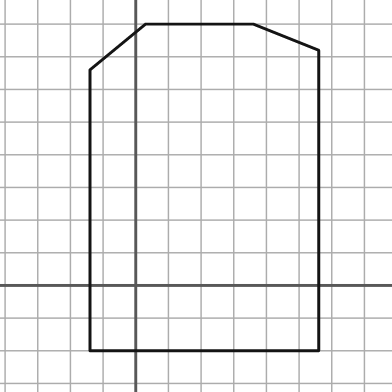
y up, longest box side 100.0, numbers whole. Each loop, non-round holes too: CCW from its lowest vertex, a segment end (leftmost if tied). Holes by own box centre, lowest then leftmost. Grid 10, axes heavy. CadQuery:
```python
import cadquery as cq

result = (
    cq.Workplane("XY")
    .moveTo(-14.0, -20.0)
    .lineTo(56.0, -20.0)
    .lineTo(56.0, 72.0)
    .lineTo(36.0, 80.0)
    .lineTo(3.0, 80.0)
    .lineTo(-14.0, 66.0)
    .close()
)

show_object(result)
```